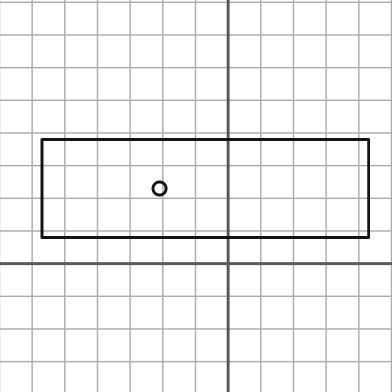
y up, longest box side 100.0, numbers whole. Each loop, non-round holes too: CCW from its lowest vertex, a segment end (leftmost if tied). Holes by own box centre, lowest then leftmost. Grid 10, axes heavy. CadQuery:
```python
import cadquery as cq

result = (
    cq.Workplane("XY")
    .moveTo(-57.0, 8.0)
    .lineTo(43.0, 8.0)
    .lineTo(43.0, 38.0)
    .lineTo(-57.0, 38.0)
    .close()
    .moveTo(-21.0, 23.0)
    .circle(2.0)
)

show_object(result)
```